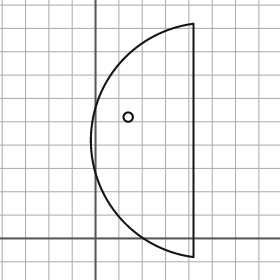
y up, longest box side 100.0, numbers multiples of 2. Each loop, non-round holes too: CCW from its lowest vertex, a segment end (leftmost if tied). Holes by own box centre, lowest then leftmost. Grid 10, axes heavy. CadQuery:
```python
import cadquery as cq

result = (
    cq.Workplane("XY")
    .moveTo(42.0, -8.0)
    .lineTo(42.0, 92.0)
    .threePointArc((-2.0, 42.0), (42.0, -8.0))
    .close()
    .moveTo(14.0, 52.0)
    .circle(2.0)
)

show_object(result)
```